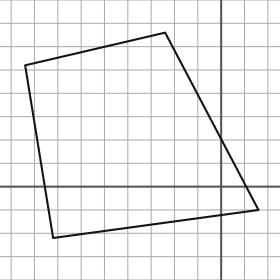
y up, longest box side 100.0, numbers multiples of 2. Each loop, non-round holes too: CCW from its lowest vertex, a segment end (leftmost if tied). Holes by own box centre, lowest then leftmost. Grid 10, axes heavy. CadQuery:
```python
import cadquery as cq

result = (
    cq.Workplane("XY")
    .moveTo(-72.0, -22.0)
    .lineTo(16.0, -10.0)
    .lineTo(-24.0, 66.0)
    .lineTo(-84.0, 52.0)
    .close()
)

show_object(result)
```